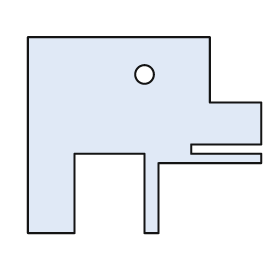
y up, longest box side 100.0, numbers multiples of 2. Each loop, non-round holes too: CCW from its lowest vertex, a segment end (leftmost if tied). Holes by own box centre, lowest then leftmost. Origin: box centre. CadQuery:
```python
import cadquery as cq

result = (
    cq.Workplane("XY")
    .moveTo(-50.0, -42.0)
    .lineTo(-30.0, -42.0)
    .lineTo(-30.0, -8.0)
    .lineTo(0.0, -8.0)
    .lineTo(0.0, -42.0)
    .lineTo(6.0, -42.0)
    .lineTo(6.0, -12.0)
    .lineTo(50.0, -12.0)
    .lineTo(50.0, -8.0)
    .lineTo(20.0, -8.0)
    .lineTo(20.0, -4.0)
    .lineTo(50.0, -4.0)
    .lineTo(50.0, 14.0)
    .lineTo(28.0, 14.0)
    .lineTo(28.0, 42.0)
    .lineTo(-50.0, 42.0)
    .close()
    .moveTo(0.0, 26.0)
    .circle(4.0)
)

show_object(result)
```